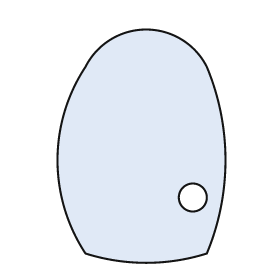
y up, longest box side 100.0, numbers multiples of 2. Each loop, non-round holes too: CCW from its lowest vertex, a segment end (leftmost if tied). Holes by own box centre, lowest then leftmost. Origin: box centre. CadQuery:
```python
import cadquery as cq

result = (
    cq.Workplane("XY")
    .moveTo(-24.0, -46.0)
    .threePointArc((2.0, -50.0), (28.0, -46.0))
    .threePointArc((36.0, -6.0), (28.0, 34.0))
    .threePointArc((2.0, 50.0), (-24.0, 34.0))
    .threePointArc((-36.0, -6.0), (-24.0, -46.0))
    .close()
    .moveTo(22.0, -22.0)
    .circle(6.0)
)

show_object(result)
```